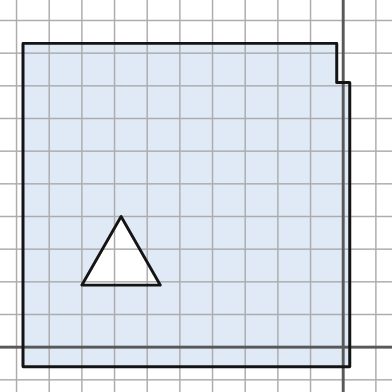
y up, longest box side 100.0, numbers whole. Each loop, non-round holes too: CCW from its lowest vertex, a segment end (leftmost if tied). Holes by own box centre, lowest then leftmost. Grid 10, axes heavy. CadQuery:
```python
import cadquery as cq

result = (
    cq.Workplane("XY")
    .moveTo(-98.0, -6.0)
    .lineTo(2.0, -6.0)
    .lineTo(2.0, 81.0)
    .lineTo(-2.0, 81.0)
    .lineTo(-2.0, 93.0)
    .lineTo(-98.0, 93.0)
    .close()
    .moveTo(-80.0, 19.0)
    .lineTo(-56.0, 19.0)
    .lineTo(-68.0, 40.0)
    .close()
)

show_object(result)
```